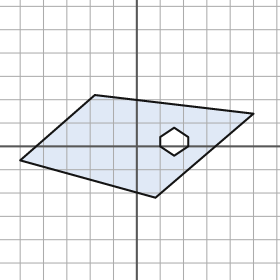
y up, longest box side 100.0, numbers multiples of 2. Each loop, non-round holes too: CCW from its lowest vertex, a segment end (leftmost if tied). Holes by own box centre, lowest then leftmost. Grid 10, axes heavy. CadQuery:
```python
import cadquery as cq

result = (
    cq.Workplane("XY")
    .moveTo(8.0, -22.0)
    .lineTo(50.0, 14.0)
    .lineTo(-18.0, 22.0)
    .lineTo(-50.0, -6.0)
    .close()
    .moveTo(16.0, -4.0)
    .lineTo(22.0, 0.0)
    .lineTo(22.0, 4.0)
    .lineTo(16.0, 8.0)
    .lineTo(10.0, 4.0)
    .lineTo(10.0, 0.0)
    .close()
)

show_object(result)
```